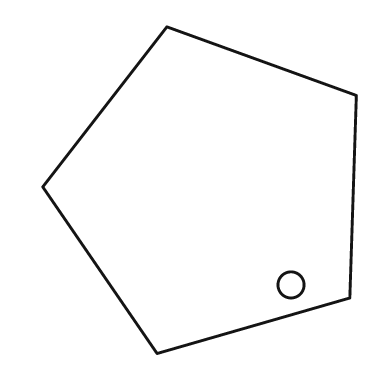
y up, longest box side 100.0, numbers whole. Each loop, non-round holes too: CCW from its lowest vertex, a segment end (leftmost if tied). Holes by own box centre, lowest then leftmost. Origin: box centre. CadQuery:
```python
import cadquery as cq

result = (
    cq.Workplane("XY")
    .moveTo(-13.0, -50.0)
    .lineTo(46.0, -33.0)
    .lineTo(48.0, 29.0)
    .lineTo(-10.0, 50.0)
    .lineTo(-48.0, 1.0)
    .close()
    .moveTo(28.0, -29.0)
    .circle(4.0)
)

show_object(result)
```